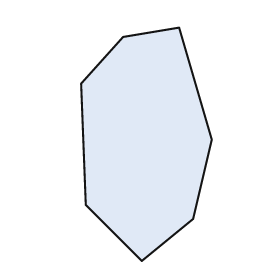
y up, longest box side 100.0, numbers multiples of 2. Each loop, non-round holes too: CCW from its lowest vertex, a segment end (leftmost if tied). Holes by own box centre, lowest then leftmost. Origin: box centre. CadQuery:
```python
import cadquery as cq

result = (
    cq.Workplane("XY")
    .moveTo(-2.0, -50.0)
    .lineTo(20.0, -32.0)
    .lineTo(28.0, 2.0)
    .lineTo(14.0, 50.0)
    .lineTo(-10.0, 46.0)
    .lineTo(-28.0, 26.0)
    .lineTo(-26.0, -26.0)
    .close()
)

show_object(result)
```